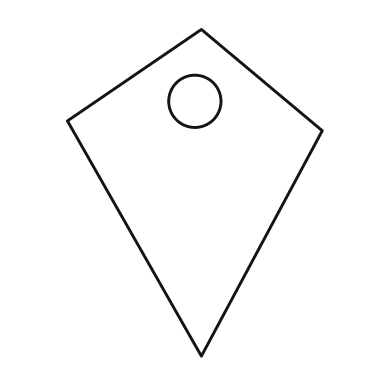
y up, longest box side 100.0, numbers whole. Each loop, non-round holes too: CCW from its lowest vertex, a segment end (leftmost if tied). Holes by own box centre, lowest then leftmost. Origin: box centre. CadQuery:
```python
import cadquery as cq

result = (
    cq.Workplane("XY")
    .moveTo(2.0, -50.0)
    .lineTo(39.0, 19.0)
    .lineTo(2.0, 50.0)
    .lineTo(-39.0, 22.0)
    .close()
    .moveTo(0.0, 28.0)
    .circle(8.0)
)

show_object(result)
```